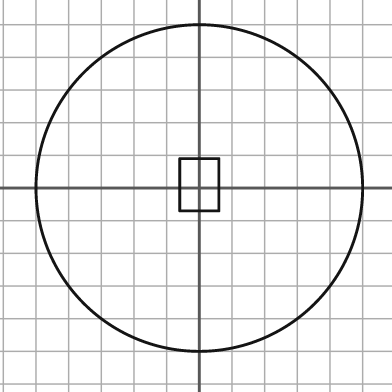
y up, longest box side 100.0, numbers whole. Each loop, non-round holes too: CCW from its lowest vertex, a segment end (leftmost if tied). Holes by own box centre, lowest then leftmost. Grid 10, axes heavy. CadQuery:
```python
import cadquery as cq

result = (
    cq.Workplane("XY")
    .moveTo(0.0, 0.0)
    .circle(50.0)
    .moveTo(-6.0, -7.0)
    .lineTo(6.0, -7.0)
    .lineTo(6.0, 9.0)
    .lineTo(-6.0, 9.0)
    .close()
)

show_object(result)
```